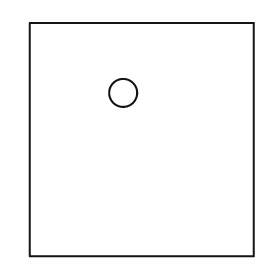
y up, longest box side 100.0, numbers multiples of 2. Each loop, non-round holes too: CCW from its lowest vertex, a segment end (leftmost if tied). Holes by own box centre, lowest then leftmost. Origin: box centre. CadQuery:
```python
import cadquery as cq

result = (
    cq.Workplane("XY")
    .moveTo(-48.0, -50.0)
    .lineTo(48.0, -50.0)
    .lineTo(48.0, 50.0)
    .lineTo(-48.0, 50.0)
    .close()
    .moveTo(-8.0, 20.0)
    .circle(6.0)
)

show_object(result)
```